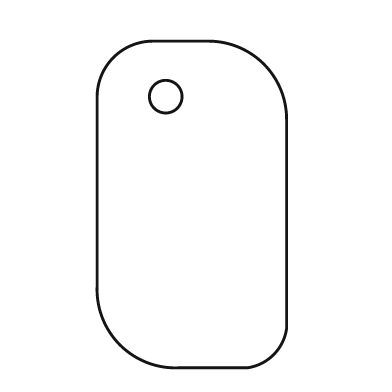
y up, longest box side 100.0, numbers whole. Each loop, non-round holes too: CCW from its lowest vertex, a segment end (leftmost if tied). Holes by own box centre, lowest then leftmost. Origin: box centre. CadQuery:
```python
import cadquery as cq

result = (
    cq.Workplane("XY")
    .moveTo(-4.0, -50.0)
    .lineTo(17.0, -50.0)
    .threePointArc((25.0, -46.0), (29.0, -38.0))
    .lineTo(29.0, 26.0)
    .threePointArc((22.0, 43.0), (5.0, 50.0))
    .lineTo(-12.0, 50.0)
    .threePointArc((-24.0, 45.0), (-29.0, 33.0))
    .lineTo(-29.0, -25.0)
    .threePointArc((-22.0, -43.0), (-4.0, -50.0))
    .close()
    .moveTo(-8.0, 33.0)
    .circle(5.0)
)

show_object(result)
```